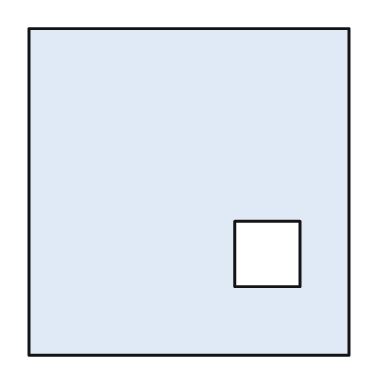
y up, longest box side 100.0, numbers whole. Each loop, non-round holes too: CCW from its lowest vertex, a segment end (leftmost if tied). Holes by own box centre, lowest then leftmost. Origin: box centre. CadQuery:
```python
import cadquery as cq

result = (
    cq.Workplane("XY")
    .moveTo(-49.0, -50.0)
    .lineTo(49.0, -50.0)
    .lineTo(49.0, 50.0)
    .lineTo(-49.0, 50.0)
    .close()
    .moveTo(14.0, -29.0)
    .lineTo(34.0, -29.0)
    .lineTo(34.0, -9.0)
    .lineTo(14.0, -9.0)
    .close()
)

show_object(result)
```